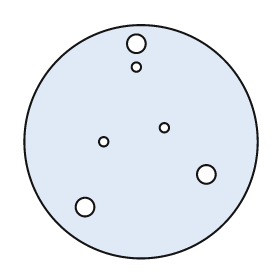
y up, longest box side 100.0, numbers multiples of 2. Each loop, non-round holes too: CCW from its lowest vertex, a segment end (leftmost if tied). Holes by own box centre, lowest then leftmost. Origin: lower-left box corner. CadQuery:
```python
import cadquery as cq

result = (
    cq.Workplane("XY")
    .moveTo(50.0, 50.0)
    .circle(50.0)
    .moveTo(26.0, 22.0)
    .circle(4.0)
    .moveTo(78.0, 36.0)
    .circle(4.0)
    .moveTo(34.0, 50.0)
    .circle(2.0)
    .moveTo(60.0, 56.0)
    .circle(2.0)
    .moveTo(48.0, 82.0)
    .circle(2.0)
    .moveTo(48.0, 92.0)
    .circle(4.0)
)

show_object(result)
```